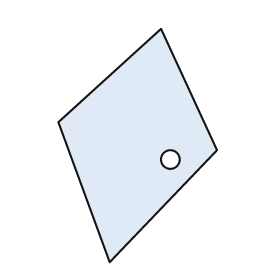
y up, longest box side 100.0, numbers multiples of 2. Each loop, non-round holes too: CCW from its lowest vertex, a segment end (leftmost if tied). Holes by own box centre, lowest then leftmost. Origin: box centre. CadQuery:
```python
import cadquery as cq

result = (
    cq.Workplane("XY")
    .moveTo(-12.0, -50.0)
    .lineTo(34.0, -2.0)
    .lineTo(10.0, 50.0)
    .lineTo(-34.0, 10.0)
    .close()
    .moveTo(14.0, -6.0)
    .circle(4.0)
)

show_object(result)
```